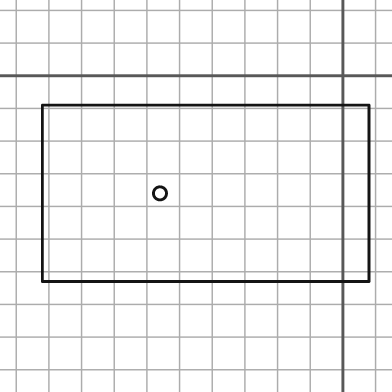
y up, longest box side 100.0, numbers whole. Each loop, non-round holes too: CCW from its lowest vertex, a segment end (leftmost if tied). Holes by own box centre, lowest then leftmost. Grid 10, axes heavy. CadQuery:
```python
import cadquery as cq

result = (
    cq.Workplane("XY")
    .moveTo(-92.0, -63.0)
    .lineTo(8.0, -63.0)
    .lineTo(8.0, -9.0)
    .lineTo(-92.0, -9.0)
    .close()
    .moveTo(-56.0, -36.0)
    .circle(2.0)
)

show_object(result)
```